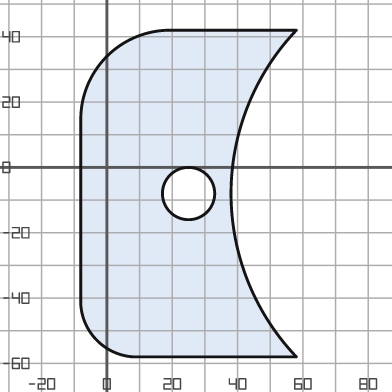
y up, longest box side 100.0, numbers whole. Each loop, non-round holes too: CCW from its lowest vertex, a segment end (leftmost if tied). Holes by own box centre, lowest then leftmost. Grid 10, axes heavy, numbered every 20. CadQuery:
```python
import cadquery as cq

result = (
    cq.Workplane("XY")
    .moveTo(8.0, -58.0)
    .lineTo(58.0, -58.0)
    .threePointArc((38.0, -8.0), (58.0, 42.0))
    .lineTo(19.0, 42.0)
    .threePointArc((0.0, 34.0), (-8.0, 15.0))
    .lineTo(-8.0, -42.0)
    .threePointArc((-3.0, -53.0), (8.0, -58.0))
    .close()
    .moveTo(25.0, -8.0)
    .circle(8.0)
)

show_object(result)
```